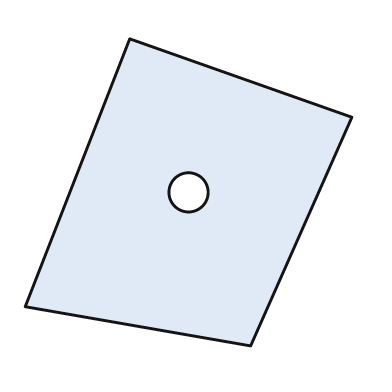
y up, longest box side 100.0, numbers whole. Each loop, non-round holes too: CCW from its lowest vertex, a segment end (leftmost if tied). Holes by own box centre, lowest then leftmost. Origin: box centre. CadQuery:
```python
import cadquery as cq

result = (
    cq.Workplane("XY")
    .moveTo(19.0, -47.0)
    .lineTo(50.0, 23.0)
    .lineTo(-18.0, 47.0)
    .lineTo(-50.0, -35.0)
    .close()
    .moveTo(0.0, 0.0)
    .circle(6.0)
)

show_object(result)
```